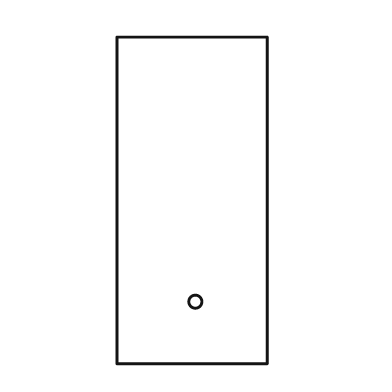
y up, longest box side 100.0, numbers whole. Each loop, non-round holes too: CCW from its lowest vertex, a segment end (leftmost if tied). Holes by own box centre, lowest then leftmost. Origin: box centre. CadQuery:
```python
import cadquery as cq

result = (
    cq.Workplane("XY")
    .moveTo(-23.0, -50.0)
    .lineTo(23.0, -50.0)
    .lineTo(23.0, 50.0)
    .lineTo(-23.0, 50.0)
    .close()
    .moveTo(1.0, -31.0)
    .circle(2.0)
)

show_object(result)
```